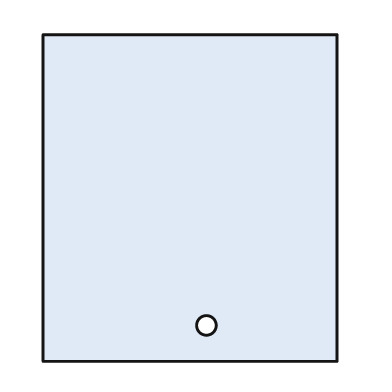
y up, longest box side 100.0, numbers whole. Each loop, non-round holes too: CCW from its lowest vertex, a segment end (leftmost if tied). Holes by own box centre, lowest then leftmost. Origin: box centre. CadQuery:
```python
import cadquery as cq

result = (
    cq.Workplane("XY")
    .moveTo(-45.0, -50.0)
    .lineTo(45.0, -50.0)
    .lineTo(45.0, 50.0)
    .lineTo(-45.0, 50.0)
    .close()
    .moveTo(5.0, -39.0)
    .circle(3.0)
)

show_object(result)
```